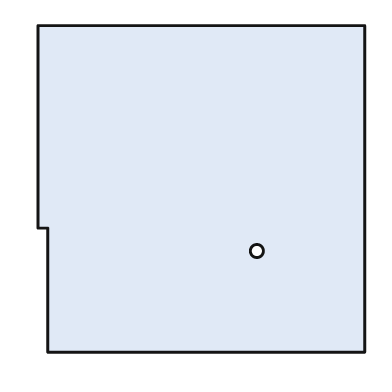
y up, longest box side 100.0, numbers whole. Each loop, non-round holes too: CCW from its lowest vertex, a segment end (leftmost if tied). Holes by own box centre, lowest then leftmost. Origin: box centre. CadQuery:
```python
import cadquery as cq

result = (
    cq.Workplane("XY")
    .moveTo(-47.0, -50.0)
    .lineTo(50.0, -50.0)
    .lineTo(50.0, 50.0)
    .lineTo(-50.0, 50.0)
    .lineTo(-50.0, -12.0)
    .lineTo(-47.0, -12.0)
    .close()
    .moveTo(17.0, -19.0)
    .circle(2.0)
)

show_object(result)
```